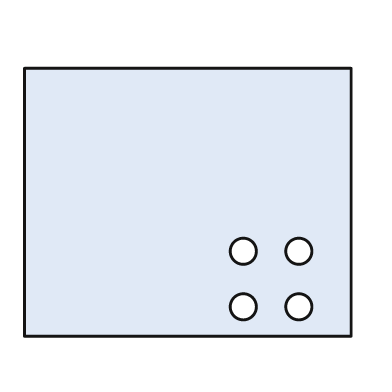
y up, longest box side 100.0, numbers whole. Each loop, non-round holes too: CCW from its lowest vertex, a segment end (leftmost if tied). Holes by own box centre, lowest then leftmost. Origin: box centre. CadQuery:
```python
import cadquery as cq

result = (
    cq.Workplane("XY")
    .moveTo(-50.0, -41.0)
    .lineTo(50.0, -41.0)
    .lineTo(50.0, 41.0)
    .lineTo(-50.0, 41.0)
    .close()
    .moveTo(17.0, -32.0)
    .circle(4.0)
    .moveTo(34.0, -32.0)
    .circle(4.0)
    .moveTo(17.0, -15.0)
    .circle(4.0)
    .moveTo(34.0, -15.0)
    .circle(4.0)
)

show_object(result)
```